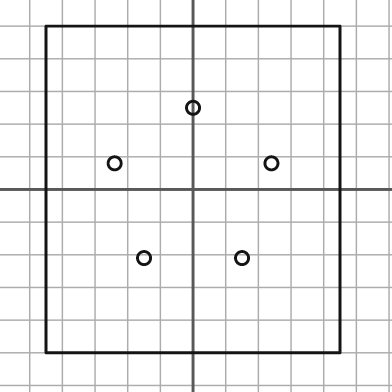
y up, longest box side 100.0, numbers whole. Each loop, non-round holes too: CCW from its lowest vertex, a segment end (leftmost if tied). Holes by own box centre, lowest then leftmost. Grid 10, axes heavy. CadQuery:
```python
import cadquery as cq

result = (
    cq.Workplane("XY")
    .moveTo(-45.0, -50.0)
    .lineTo(45.0, -50.0)
    .lineTo(45.0, 50.0)
    .lineTo(-45.0, 50.0)
    .close()
    .moveTo(-15.0, -21.0)
    .circle(2.0)
    .moveTo(15.0, -21.0)
    .circle(2.0)
    .moveTo(-24.0, 8.0)
    .circle(2.0)
    .moveTo(24.0, 8.0)
    .circle(2.0)
    .moveTo(0.0, 25.0)
    .circle(2.0)
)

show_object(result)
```